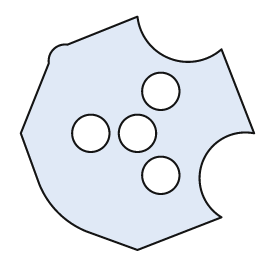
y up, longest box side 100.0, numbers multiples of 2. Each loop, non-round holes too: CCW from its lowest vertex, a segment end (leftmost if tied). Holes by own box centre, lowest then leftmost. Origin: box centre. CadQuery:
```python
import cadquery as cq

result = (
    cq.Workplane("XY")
    .moveTo(0.0, -50.0)
    .lineTo(36.0, -36.0)
    .threePointArc((28.0, -12.0), (50.0, 0.0))
    .lineTo(36.0, 36.0)
    .threePointArc((14.0, 32.0), (0.0, 50.0))
    .lineTo(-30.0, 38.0)
    .threePointArc((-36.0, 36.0), (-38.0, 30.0))
    .lineTo(-50.0, 0.0)
    .lineTo(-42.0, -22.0)
    .threePointArc((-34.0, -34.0), (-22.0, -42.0))
    .close()
    .moveTo(10.0, -18.0)
    .circle(8.0)
    .moveTo(-20.0, 0.0)
    .circle(8.0)
    .moveTo(0.0, 0.0)
    .circle(8.0)
    .moveTo(10.0, 18.0)
    .circle(8.0)
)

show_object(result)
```